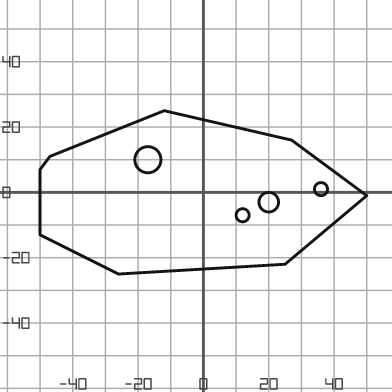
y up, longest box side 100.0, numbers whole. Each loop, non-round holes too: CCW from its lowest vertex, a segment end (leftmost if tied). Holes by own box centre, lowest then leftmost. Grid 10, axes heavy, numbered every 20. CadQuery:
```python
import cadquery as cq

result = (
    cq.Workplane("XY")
    .moveTo(-26.0, -25.0)
    .lineTo(25.0, -22.0)
    .lineTo(50.0, -1.0)
    .lineTo(27.0, 16.0)
    .lineTo(-12.0, 25.0)
    .lineTo(-47.0, 11.0)
    .lineTo(-50.0, 7.0)
    .lineTo(-50.0, -13.0)
    .close()
    .moveTo(12.0, -7.0)
    .circle(2.0)
    .moveTo(20.0, -3.0)
    .circle(3.0)
    .moveTo(36.0, 1.0)
    .circle(2.0)
    .moveTo(-17.0, 10.0)
    .circle(4.0)
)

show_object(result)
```